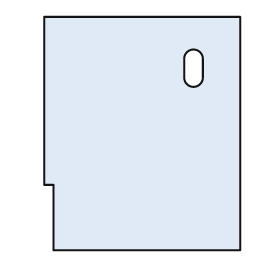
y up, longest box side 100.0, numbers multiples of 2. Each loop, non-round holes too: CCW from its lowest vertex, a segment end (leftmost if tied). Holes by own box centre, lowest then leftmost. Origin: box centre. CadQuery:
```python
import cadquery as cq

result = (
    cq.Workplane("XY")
    .moveTo(-38.0, -50.0)
    .lineTo(42.0, -50.0)
    .lineTo(42.0, 50.0)
    .lineTo(-42.0, 50.0)
    .lineTo(-42.0, -22.0)
    .lineTo(-38.0, -22.0)
    .close()
    .moveTo(18.0, 24.0)
    .threePointArc((22.0, 20.0), (26.0, 24.0))
    .lineTo(26.0, 32.0)
    .threePointArc((22.0, 36.0), (18.0, 32.0))
    .close()
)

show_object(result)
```